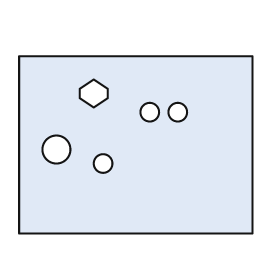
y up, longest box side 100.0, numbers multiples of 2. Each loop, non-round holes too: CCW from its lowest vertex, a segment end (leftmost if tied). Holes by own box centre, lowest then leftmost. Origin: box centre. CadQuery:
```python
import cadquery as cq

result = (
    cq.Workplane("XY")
    .moveTo(-50.0, -38.0)
    .lineTo(50.0, -38.0)
    .lineTo(50.0, 38.0)
    .lineTo(-50.0, 38.0)
    .close()
    .moveTo(-14.0, -8.0)
    .circle(4.0)
    .moveTo(-34.0, -2.0)
    .circle(6.0)
    .moveTo(6.0, 14.0)
    .circle(4.0)
    .moveTo(18.0, 14.0)
    .circle(4.0)
    .moveTo(-18.0, 16.0)
    .lineTo(-12.0, 20.0)
    .lineTo(-12.0, 24.0)
    .lineTo(-18.0, 28.0)
    .lineTo(-24.0, 24.0)
    .lineTo(-24.0, 20.0)
    .close()
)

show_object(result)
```